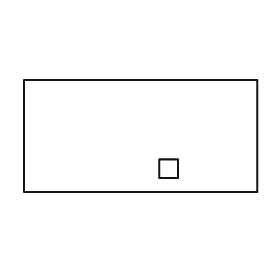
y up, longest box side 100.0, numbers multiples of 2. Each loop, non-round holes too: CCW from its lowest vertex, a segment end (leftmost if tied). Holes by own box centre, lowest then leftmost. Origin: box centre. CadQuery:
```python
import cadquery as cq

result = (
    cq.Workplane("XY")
    .moveTo(-50.0, -24.0)
    .lineTo(50.0, -24.0)
    .lineTo(50.0, 24.0)
    .lineTo(-50.0, 24.0)
    .close()
    .moveTo(8.0, -18.0)
    .lineTo(16.0, -18.0)
    .lineTo(16.0, -10.0)
    .lineTo(8.0, -10.0)
    .close()
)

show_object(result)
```